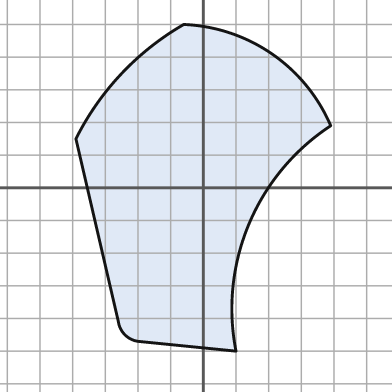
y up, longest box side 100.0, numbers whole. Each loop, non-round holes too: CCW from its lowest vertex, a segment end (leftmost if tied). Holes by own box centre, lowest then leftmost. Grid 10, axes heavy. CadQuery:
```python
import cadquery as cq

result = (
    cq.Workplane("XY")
    .moveTo(10.0, -50.0)
    .threePointArc((14.0, -11.0), (39.0, 19.0))
    .threePointArc((21.0, 41.0), (-6.0, 50.0))
    .threePointArc((-25.0, 35.0), (-39.0, 15.0))
    .lineTo(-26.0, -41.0)
    .threePointArc((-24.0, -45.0), (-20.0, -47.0))
    .close()
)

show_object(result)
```